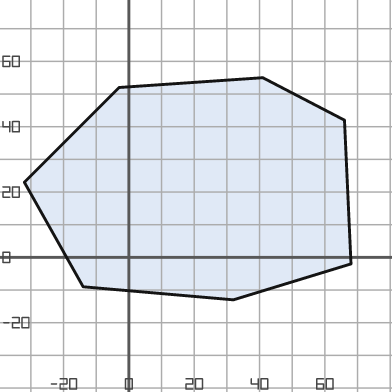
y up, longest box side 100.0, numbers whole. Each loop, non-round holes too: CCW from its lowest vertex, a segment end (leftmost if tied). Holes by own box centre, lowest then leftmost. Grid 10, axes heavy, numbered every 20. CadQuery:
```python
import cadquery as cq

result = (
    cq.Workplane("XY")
    .moveTo(32.0, -13.0)
    .lineTo(68.0, -2.0)
    .lineTo(66.0, 42.0)
    .lineTo(41.0, 55.0)
    .lineTo(-3.0, 52.0)
    .lineTo(-32.0, 23.0)
    .lineTo(-14.0, -9.0)
    .close()
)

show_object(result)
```